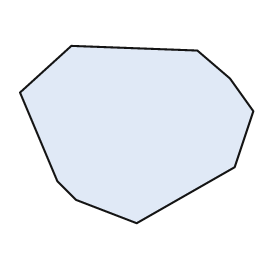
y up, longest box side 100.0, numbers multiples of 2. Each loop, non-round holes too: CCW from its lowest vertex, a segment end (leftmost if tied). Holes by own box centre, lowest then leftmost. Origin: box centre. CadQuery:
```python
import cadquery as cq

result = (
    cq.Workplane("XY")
    .moveTo(0.0, -38.0)
    .lineTo(42.0, -14.0)
    .lineTo(50.0, 10.0)
    .lineTo(40.0, 24.0)
    .lineTo(26.0, 36.0)
    .lineTo(-28.0, 38.0)
    .lineTo(-50.0, 18.0)
    .lineTo(-34.0, -20.0)
    .lineTo(-26.0, -28.0)
    .close()
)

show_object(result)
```